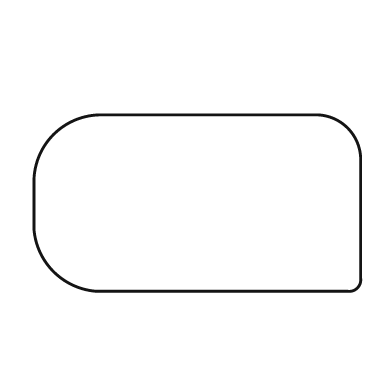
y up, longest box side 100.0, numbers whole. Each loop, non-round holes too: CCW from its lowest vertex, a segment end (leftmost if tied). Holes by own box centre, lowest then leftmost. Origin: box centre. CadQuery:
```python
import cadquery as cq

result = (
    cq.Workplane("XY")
    .moveTo(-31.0, -27.0)
    .lineTo(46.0, -27.0)
    .threePointArc((49.0, -26.0), (50.0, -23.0))
    .lineTo(50.0, 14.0)
    .threePointArc((46.0, 23.0), (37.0, 27.0))
    .lineTo(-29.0, 27.0)
    .threePointArc((-44.0, 21.0), (-50.0, 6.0))
    .lineTo(-50.0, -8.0)
    .threePointArc((-44.0, -21.0), (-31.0, -27.0))
    .close()
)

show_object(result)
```